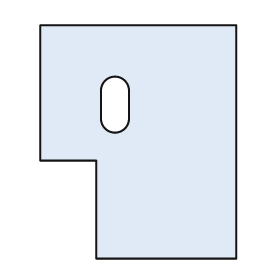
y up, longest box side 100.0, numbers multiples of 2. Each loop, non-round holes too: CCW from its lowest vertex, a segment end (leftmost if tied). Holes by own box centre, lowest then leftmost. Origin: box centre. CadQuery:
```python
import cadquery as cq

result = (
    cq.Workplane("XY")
    .moveTo(-18.0, -50.0)
    .lineTo(42.0, -50.0)
    .lineTo(42.0, 50.0)
    .lineTo(-42.0, 50.0)
    .lineTo(-42.0, -8.0)
    .lineTo(-18.0, -8.0)
    .close()
    .moveTo(-16.0, 10.0)
    .threePointArc((-10.0, 4.0), (-4.0, 10.0))
    .lineTo(-4.0, 22.0)
    .threePointArc((-10.0, 28.0), (-16.0, 22.0))
    .close()
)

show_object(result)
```